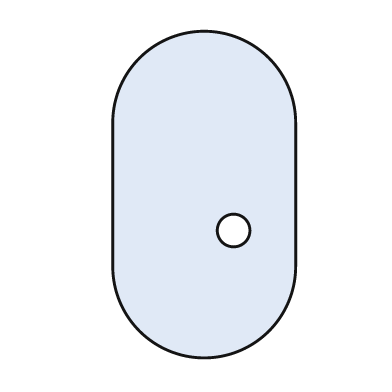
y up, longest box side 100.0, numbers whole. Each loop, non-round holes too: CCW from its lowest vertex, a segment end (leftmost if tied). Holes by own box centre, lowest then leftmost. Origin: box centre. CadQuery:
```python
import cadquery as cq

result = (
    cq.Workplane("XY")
    .moveTo(-28.0, -22.0)
    .threePointArc((0.0, -50.0), (28.0, -22.0))
    .lineTo(28.0, 22.0)
    .threePointArc((0.0, 50.0), (-28.0, 22.0))
    .close()
    .moveTo(9.0, -11.0)
    .circle(5.0)
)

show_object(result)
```